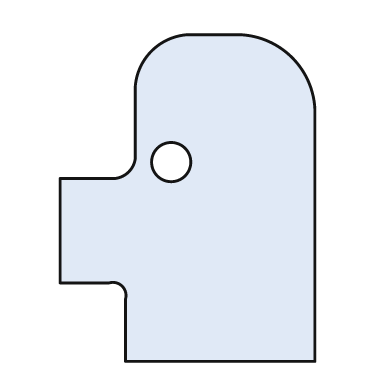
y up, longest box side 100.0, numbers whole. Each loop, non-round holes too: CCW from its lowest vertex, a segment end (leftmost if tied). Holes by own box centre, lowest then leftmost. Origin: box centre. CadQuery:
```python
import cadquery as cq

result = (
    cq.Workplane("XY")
    .moveTo(-19.0, -50.0)
    .lineTo(39.0, -50.0)
    .lineTo(39.0, 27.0)
    .threePointArc((32.0, 43.0), (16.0, 50.0))
    .lineTo(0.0, 50.0)
    .threePointArc((-11.0, 45.0), (-16.0, 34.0))
    .lineTo(-16.0, 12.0)
    .threePointArc((-18.0, 8.0), (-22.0, 6.0))
    .lineTo(-39.0, 6.0)
    .lineTo(-39.0, -26.0)
    .lineTo(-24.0, -26.0)
    .threePointArc((-20.0, -27.0), (-19.0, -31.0))
    .close()
    .moveTo(-5.0, 11.0)
    .circle(6.0)
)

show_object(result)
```